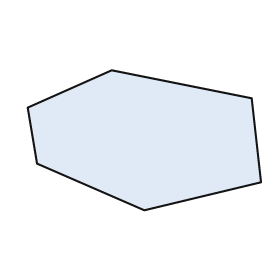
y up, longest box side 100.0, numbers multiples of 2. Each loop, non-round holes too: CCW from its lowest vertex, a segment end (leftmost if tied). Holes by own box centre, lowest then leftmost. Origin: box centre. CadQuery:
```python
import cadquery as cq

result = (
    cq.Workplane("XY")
    .moveTo(0.0, -30.0)
    .lineTo(50.0, -18.0)
    .lineTo(46.0, 18.0)
    .lineTo(-14.0, 30.0)
    .lineTo(-50.0, 14.0)
    .lineTo(-46.0, -10.0)
    .close()
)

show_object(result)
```